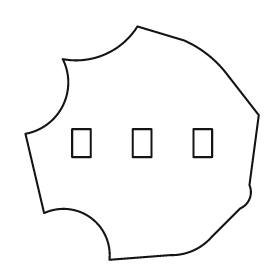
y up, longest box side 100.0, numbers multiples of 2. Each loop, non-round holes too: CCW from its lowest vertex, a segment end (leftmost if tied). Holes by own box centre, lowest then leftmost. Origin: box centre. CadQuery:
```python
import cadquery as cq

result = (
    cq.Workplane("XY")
    .moveTo(-14.0, -50.0)
    .lineTo(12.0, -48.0)
    .threePointArc((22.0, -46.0), (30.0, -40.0))
    .lineTo(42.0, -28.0)
    .threePointArc((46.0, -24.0), (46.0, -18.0))
    .lineTo(50.0, 12.0)
    .lineTo(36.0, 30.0)
    .threePointArc((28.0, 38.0), (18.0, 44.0))
    .lineTo(-2.0, 50.0)
    .threePointArc((-16.0, 38.0), (-34.0, 36.0))
    .threePointArc((-34.0, 16.0), (-50.0, 4.0))
    .lineTo(-42.0, -30.0)
    .threePointArc((-22.0, -32.0), (-14.0, -50.0))
    .close()
    .moveTo(-30.0, -6.0)
    .lineTo(-22.0, -6.0)
    .lineTo(-22.0, 6.0)
    .lineTo(-30.0, 6.0)
    .close()
    .moveTo(-4.0, -6.0)
    .lineTo(4.0, -6.0)
    .lineTo(4.0, 6.0)
    .lineTo(-4.0, 6.0)
    .close()
    .moveTo(22.0, -6.0)
    .lineTo(30.0, -6.0)
    .lineTo(30.0, 6.0)
    .lineTo(22.0, 6.0)
    .close()
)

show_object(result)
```